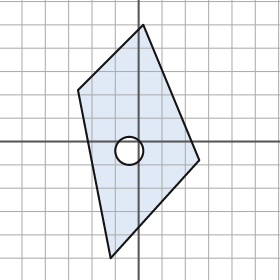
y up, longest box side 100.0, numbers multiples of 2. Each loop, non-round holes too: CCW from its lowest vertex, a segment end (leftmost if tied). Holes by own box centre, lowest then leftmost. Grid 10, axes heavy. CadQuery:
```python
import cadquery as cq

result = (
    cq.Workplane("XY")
    .moveTo(-12.0, -50.0)
    .lineTo(26.0, -8.0)
    .lineTo(2.0, 50.0)
    .lineTo(-26.0, 22.0)
    .close()
    .moveTo(-4.0, -4.0)
    .circle(6.0)
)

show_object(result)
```